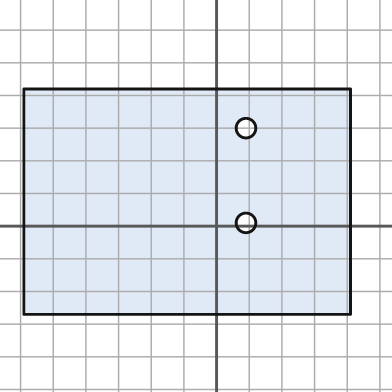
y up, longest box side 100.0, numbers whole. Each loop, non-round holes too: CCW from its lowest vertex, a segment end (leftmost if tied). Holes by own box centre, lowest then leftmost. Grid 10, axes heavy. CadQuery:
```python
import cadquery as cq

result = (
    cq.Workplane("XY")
    .moveTo(-59.0, -27.0)
    .lineTo(41.0, -27.0)
    .lineTo(41.0, 42.0)
    .lineTo(-59.0, 42.0)
    .close()
    .moveTo(9.0, 1.0)
    .circle(3.0)
    .moveTo(9.0, 30.0)
    .circle(3.0)
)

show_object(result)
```